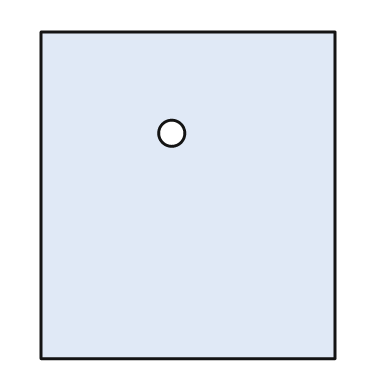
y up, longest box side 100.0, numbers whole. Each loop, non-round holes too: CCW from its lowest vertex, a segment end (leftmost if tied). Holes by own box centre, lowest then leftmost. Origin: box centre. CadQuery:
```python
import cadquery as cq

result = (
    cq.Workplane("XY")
    .moveTo(-45.0, -50.0)
    .lineTo(45.0, -50.0)
    .lineTo(45.0, 50.0)
    .lineTo(-45.0, 50.0)
    .close()
    .moveTo(-5.0, 19.0)
    .circle(4.0)
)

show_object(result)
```